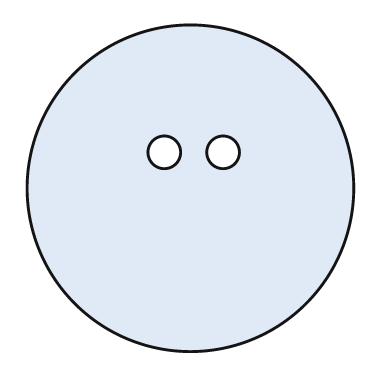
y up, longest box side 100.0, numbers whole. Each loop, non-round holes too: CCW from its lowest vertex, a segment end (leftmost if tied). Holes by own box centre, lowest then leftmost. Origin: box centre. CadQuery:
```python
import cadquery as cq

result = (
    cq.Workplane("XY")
    .moveTo(0.0, 0.0)
    .circle(50.0)
    .moveTo(-8.0, 11.0)
    .circle(5.0)
    .moveTo(10.0, 11.0)
    .circle(5.0)
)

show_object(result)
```